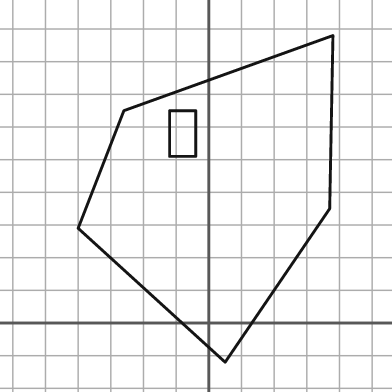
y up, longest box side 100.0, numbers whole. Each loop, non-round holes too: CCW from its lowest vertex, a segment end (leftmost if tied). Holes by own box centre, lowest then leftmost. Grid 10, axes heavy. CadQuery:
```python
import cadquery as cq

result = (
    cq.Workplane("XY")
    .moveTo(5.0, -12.0)
    .lineTo(37.0, 35.0)
    .lineTo(38.0, 88.0)
    .lineTo(-26.0, 65.0)
    .lineTo(-40.0, 29.0)
    .close()
    .moveTo(-12.0, 51.0)
    .lineTo(-4.0, 51.0)
    .lineTo(-4.0, 65.0)
    .lineTo(-12.0, 65.0)
    .close()
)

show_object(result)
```